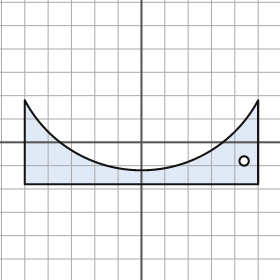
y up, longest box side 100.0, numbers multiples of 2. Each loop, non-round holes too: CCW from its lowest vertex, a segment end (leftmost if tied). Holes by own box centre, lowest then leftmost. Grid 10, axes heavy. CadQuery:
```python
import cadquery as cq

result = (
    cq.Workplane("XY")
    .moveTo(-50.0, -18.0)
    .lineTo(50.0, -18.0)
    .lineTo(50.0, 18.0)
    .threePointArc((0.0, -12.0), (-50.0, 18.0))
    .close()
    .moveTo(44.0, -8.0)
    .circle(2.0)
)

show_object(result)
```